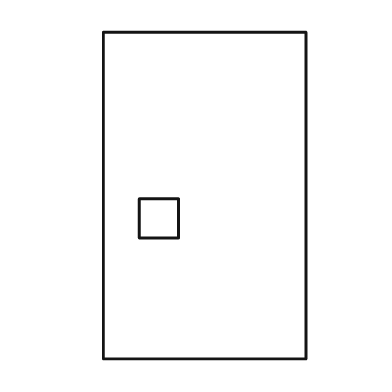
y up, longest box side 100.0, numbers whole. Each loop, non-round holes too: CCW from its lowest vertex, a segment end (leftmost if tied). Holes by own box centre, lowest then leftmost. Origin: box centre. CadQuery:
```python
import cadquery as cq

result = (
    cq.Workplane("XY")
    .moveTo(-31.0, -50.0)
    .lineTo(31.0, -50.0)
    .lineTo(31.0, 50.0)
    .lineTo(-31.0, 50.0)
    .close()
    .moveTo(-20.0, -13.0)
    .lineTo(-8.0, -13.0)
    .lineTo(-8.0, -1.0)
    .lineTo(-20.0, -1.0)
    .close()
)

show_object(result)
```